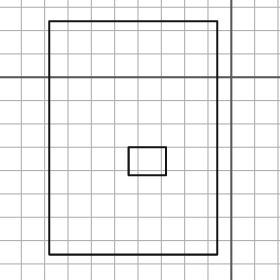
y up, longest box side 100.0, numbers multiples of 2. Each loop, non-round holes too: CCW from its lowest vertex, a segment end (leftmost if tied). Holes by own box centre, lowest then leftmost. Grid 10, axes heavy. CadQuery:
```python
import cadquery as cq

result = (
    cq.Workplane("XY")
    .moveTo(-78.0, -76.0)
    .lineTo(-6.0, -76.0)
    .lineTo(-6.0, 24.0)
    .lineTo(-78.0, 24.0)
    .close()
    .moveTo(-44.0, -42.0)
    .lineTo(-28.0, -42.0)
    .lineTo(-28.0, -30.0)
    .lineTo(-44.0, -30.0)
    .close()
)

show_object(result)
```